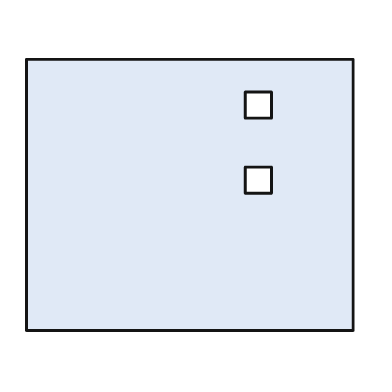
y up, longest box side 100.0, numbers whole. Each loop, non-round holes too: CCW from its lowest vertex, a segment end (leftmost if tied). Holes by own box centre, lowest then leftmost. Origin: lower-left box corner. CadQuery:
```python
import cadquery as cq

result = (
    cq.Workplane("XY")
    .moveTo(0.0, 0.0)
    .lineTo(100.0, 0.0)
    .lineTo(100.0, 83.0)
    .lineTo(0.0, 83.0)
    .close()
    .moveTo(67.0, 42.0)
    .lineTo(75.0, 42.0)
    .lineTo(75.0, 50.0)
    .lineTo(67.0, 50.0)
    .close()
    .moveTo(67.0, 65.0)
    .lineTo(75.0, 65.0)
    .lineTo(75.0, 73.0)
    .lineTo(67.0, 73.0)
    .close()
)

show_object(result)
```